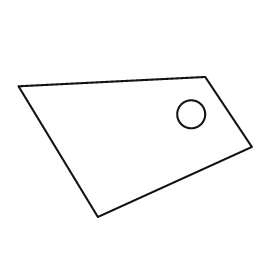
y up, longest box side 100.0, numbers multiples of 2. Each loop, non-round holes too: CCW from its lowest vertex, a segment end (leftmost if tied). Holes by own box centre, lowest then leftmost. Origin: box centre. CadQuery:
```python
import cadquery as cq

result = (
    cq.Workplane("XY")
    .moveTo(-16.0, -30.0)
    .lineTo(50.0, 0.0)
    .lineTo(30.0, 30.0)
    .lineTo(-50.0, 26.0)
    .close()
    .moveTo(24.0, 14.0)
    .circle(6.0)
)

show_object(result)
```